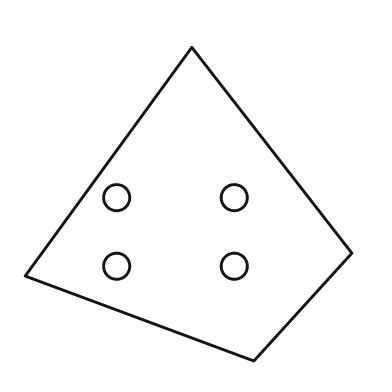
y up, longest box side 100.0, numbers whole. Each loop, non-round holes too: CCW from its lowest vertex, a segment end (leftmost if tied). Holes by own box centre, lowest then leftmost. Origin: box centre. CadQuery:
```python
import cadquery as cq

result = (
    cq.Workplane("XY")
    .moveTo(20.0, -48.0)
    .lineTo(50.0, -15.0)
    .lineTo(1.0, 48.0)
    .lineTo(-50.0, -22.0)
    .close()
    .moveTo(-22.0, -19.0)
    .circle(4.0)
    .moveTo(14.0, -19.0)
    .circle(4.0)
    .moveTo(-22.0, 2.0)
    .circle(4.0)
    .moveTo(14.0, 2.0)
    .circle(4.0)
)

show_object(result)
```